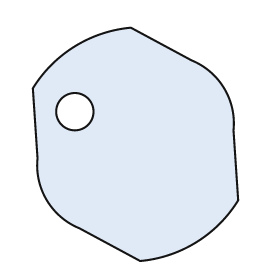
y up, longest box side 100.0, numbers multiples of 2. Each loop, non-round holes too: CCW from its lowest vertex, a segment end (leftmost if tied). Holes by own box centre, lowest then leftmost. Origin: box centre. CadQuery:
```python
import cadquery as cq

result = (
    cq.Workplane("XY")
    .moveTo(2.0, -50.0)
    .threePointArc((26.0, -42.0), (44.0, -24.0))
    .lineTo(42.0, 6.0)
    .threePointArc((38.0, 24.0), (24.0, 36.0))
    .lineTo(-2.0, 50.0)
    .threePointArc((-26.0, 42.0), (-44.0, 24.0))
    .lineTo(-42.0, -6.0)
    .threePointArc((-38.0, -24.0), (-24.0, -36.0))
    .close()
    .moveTo(-26.0, 14.0)
    .circle(8.0)
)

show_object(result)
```